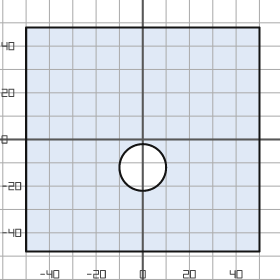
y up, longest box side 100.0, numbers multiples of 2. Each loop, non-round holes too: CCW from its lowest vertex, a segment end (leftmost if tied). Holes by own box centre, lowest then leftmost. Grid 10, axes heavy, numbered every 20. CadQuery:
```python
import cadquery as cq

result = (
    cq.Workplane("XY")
    .moveTo(-50.0, -48.0)
    .lineTo(50.0, -48.0)
    .lineTo(50.0, 48.0)
    .lineTo(-50.0, 48.0)
    .close()
    .moveTo(0.0, -12.0)
    .circle(10.0)
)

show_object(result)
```